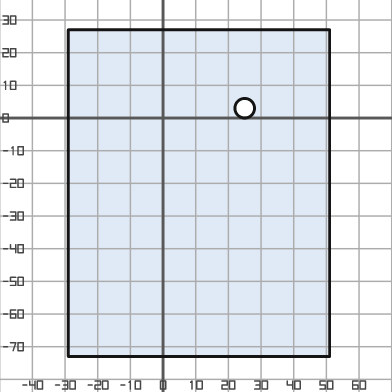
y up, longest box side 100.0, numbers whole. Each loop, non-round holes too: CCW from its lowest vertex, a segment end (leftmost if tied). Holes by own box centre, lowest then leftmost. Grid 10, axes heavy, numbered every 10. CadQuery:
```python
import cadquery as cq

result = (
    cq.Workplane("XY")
    .moveTo(-29.0, -73.0)
    .lineTo(51.0, -73.0)
    .lineTo(51.0, 27.0)
    .lineTo(-29.0, 27.0)
    .close()
    .moveTo(25.0, 3.0)
    .circle(3.0)
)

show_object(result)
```